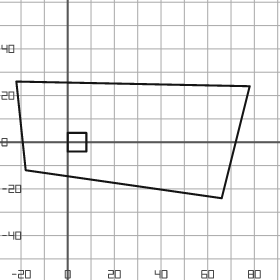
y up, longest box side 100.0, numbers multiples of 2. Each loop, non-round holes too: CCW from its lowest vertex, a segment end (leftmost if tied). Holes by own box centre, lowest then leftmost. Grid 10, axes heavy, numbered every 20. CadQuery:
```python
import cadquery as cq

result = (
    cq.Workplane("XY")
    .moveTo(66.0, -24.0)
    .lineTo(78.0, 24.0)
    .lineTo(-22.0, 26.0)
    .lineTo(-18.0, -12.0)
    .close()
    .moveTo(0.0, -4.0)
    .lineTo(8.0, -4.0)
    .lineTo(8.0, 4.0)
    .lineTo(0.0, 4.0)
    .close()
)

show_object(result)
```